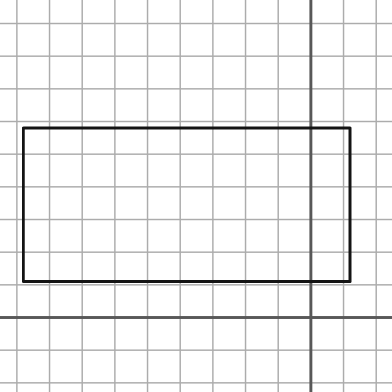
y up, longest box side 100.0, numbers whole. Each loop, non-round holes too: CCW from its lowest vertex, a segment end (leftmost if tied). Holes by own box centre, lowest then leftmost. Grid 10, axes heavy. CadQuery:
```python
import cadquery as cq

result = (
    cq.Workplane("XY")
    .moveTo(-88.0, 11.0)
    .lineTo(12.0, 11.0)
    .lineTo(12.0, 58.0)
    .lineTo(-88.0, 58.0)
    .close()
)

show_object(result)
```